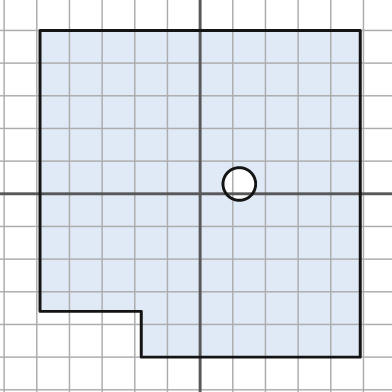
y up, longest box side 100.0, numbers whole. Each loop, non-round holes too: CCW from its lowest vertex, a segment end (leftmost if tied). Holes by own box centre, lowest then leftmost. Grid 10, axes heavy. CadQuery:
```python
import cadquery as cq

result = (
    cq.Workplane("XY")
    .moveTo(-18.0, -50.0)
    .lineTo(49.0, -50.0)
    .lineTo(49.0, 50.0)
    .lineTo(-49.0, 50.0)
    .lineTo(-49.0, -36.0)
    .lineTo(-18.0, -36.0)
    .close()
    .moveTo(12.0, 3.0)
    .circle(5.0)
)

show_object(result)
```